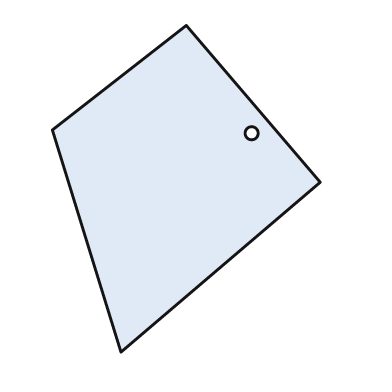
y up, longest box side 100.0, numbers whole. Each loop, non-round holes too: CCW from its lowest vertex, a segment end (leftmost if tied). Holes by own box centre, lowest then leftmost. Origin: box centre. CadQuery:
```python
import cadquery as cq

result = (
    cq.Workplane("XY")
    .moveTo(-20.0, -50.0)
    .lineTo(41.0, 2.0)
    .lineTo(0.0, 50.0)
    .lineTo(-41.0, 18.0)
    .close()
    .moveTo(20.0, 17.0)
    .circle(2.0)
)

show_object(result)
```